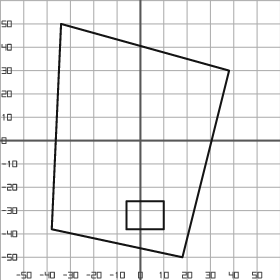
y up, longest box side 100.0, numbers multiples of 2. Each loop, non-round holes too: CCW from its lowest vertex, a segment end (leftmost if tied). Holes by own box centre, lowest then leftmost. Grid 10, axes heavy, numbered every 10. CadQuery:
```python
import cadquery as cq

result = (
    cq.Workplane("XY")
    .moveTo(18.0, -50.0)
    .lineTo(38.0, 30.0)
    .lineTo(-34.0, 50.0)
    .lineTo(-38.0, -38.0)
    .close()
    .moveTo(-6.0, -38.0)
    .lineTo(10.0, -38.0)
    .lineTo(10.0, -26.0)
    .lineTo(-6.0, -26.0)
    .close()
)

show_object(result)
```